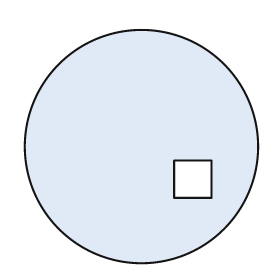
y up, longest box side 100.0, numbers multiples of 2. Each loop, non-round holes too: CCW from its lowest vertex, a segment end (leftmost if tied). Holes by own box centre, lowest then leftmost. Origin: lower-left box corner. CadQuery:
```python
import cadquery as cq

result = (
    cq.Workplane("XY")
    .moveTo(50.0, 50.0)
    .circle(50.0)
    .moveTo(64.0, 28.0)
    .lineTo(80.0, 28.0)
    .lineTo(80.0, 44.0)
    .lineTo(64.0, 44.0)
    .close()
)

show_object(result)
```